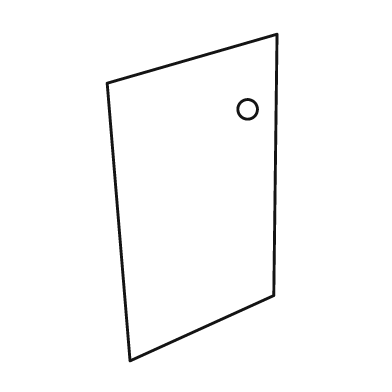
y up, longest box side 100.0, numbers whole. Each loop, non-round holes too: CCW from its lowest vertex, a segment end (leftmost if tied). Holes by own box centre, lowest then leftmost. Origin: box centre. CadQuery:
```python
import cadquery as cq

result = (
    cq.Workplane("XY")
    .moveTo(-19.0, -50.0)
    .lineTo(25.0, -30.0)
    .lineTo(26.0, 50.0)
    .lineTo(-26.0, 35.0)
    .close()
    .moveTo(17.0, 27.0)
    .circle(3.0)
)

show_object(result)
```